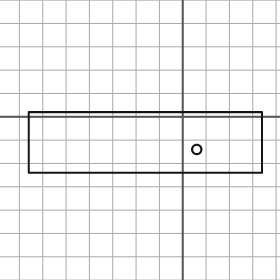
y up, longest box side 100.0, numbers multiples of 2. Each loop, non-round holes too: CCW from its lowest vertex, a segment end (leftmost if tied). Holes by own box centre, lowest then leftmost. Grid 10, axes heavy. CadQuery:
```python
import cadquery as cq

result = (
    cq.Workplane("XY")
    .moveTo(-66.0, -24.0)
    .lineTo(34.0, -24.0)
    .lineTo(34.0, 2.0)
    .lineTo(-66.0, 2.0)
    .close()
    .moveTo(6.0, -14.0)
    .circle(2.0)
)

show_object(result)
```